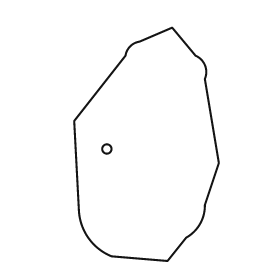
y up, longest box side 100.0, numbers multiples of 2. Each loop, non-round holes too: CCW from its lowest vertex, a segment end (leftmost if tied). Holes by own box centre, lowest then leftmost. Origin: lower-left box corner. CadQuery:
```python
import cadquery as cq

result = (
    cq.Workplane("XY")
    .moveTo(40.0, 0.0)
    .lineTo(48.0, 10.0)
    .threePointArc((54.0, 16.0), (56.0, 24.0))
    .lineTo(62.0, 42.0)
    .lineTo(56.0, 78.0)
    .threePointArc((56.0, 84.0), (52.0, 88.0))
    .lineTo(42.0, 100.0)
    .lineTo(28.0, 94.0)
    .threePointArc((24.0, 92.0), (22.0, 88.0))
    .lineTo(0.0, 60.0)
    .lineTo(2.0, 22.0)
    .threePointArc((6.0, 10.0), (16.0, 2.0))
    .close()
    .moveTo(14.0, 48.0)
    .circle(2.0)
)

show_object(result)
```